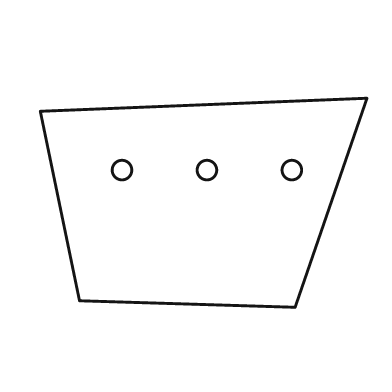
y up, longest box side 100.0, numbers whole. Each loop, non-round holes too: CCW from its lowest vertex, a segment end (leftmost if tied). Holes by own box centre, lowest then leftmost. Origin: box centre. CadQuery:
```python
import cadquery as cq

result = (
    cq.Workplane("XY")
    .moveTo(28.0, -32.0)
    .lineTo(50.0, 32.0)
    .lineTo(-50.0, 28.0)
    .lineTo(-38.0, -30.0)
    .close()
    .moveTo(-25.0, 10.0)
    .circle(3.0)
    .moveTo(1.0, 10.0)
    .circle(3.0)
    .moveTo(27.0, 10.0)
    .circle(3.0)
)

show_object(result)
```